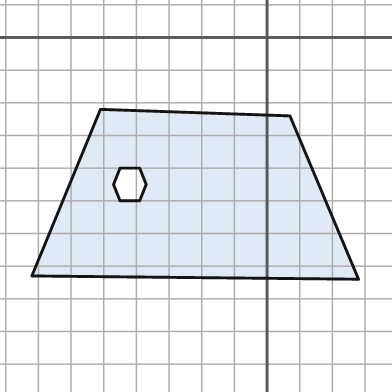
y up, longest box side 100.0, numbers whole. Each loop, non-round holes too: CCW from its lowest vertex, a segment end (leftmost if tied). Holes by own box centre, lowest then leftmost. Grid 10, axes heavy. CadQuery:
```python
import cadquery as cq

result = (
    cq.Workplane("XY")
    .moveTo(28.0, -74.0)
    .lineTo(7.0, -24.0)
    .lineTo(-51.0, -22.0)
    .lineTo(-72.0, -73.0)
    .close()
    .moveTo(-45.0, -50.0)
    .lineTo(-39.0, -50.0)
    .lineTo(-37.0, -45.0)
    .lineTo(-39.0, -40.0)
    .lineTo(-45.0, -40.0)
    .lineTo(-47.0, -45.0)
    .close()
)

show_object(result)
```